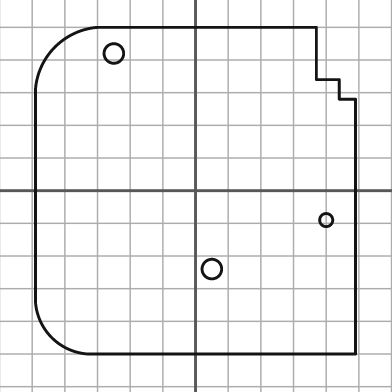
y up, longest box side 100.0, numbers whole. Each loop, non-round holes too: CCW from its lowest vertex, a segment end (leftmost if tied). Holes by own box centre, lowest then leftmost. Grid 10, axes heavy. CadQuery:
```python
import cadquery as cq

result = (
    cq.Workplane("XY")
    .moveTo(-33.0, -50.0)
    .lineTo(49.0, -50.0)
    .lineTo(49.0, 28.0)
    .lineTo(44.0, 28.0)
    .lineTo(44.0, 34.0)
    .lineTo(37.0, 34.0)
    .lineTo(37.0, 50.0)
    .lineTo(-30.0, 50.0)
    .threePointArc((-43.0, 44.0), (-49.0, 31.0))
    .lineTo(-49.0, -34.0)
    .threePointArc((-44.0, -45.0), (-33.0, -50.0))
    .close()
    .moveTo(5.0, -24.0)
    .circle(3.0)
    .moveTo(40.0, -9.0)
    .circle(2.0)
    .moveTo(-25.0, 42.0)
    .circle(3.0)
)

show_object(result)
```